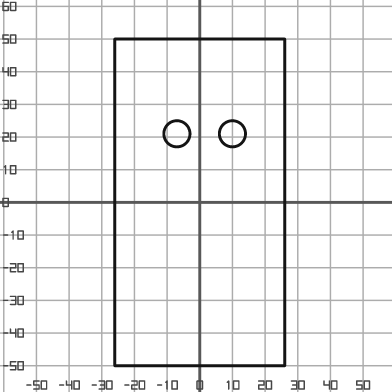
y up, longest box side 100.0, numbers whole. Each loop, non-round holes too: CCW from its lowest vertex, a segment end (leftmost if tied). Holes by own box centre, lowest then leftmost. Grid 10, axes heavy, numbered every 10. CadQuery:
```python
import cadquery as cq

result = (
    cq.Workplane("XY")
    .moveTo(-26.0, -50.0)
    .lineTo(26.0, -50.0)
    .lineTo(26.0, 50.0)
    .lineTo(-26.0, 50.0)
    .close()
    .moveTo(-7.0, 21.0)
    .circle(4.0)
    .moveTo(10.0, 21.0)
    .circle(4.0)
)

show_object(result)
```